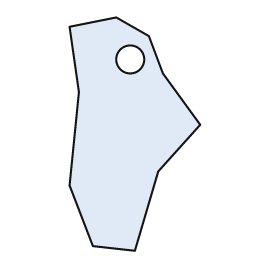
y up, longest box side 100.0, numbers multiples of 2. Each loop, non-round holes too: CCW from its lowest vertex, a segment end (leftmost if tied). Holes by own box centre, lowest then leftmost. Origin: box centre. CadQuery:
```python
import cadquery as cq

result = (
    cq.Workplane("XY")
    .moveTo(0.0, -50.0)
    .lineTo(10.0, -16.0)
    .lineTo(28.0, 4.0)
    .lineTo(12.0, 26.0)
    .lineTo(6.0, 42.0)
    .lineTo(-8.0, 50.0)
    .lineTo(-28.0, 46.0)
    .lineTo(-24.0, 18.0)
    .lineTo(-28.0, -22.0)
    .lineTo(-18.0, -48.0)
    .close()
    .moveTo(-2.0, 32.0)
    .circle(6.0)
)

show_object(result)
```